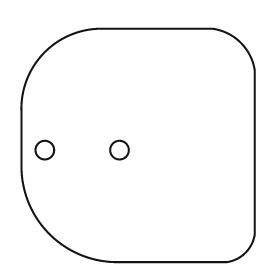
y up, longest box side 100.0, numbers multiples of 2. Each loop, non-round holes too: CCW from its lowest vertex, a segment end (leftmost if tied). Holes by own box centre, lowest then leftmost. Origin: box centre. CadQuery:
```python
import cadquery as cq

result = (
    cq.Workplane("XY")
    .moveTo(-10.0, -50.0)
    .lineTo(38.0, -50.0)
    .threePointArc((46.0, -46.0), (50.0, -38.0))
    .lineTo(50.0, 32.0)
    .threePointArc((44.0, 44.0), (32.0, 50.0))
    .lineTo(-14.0, 50.0)
    .threePointArc((-40.0, 40.0), (-50.0, 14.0))
    .lineTo(-50.0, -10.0)
    .threePointArc((-38.0, -38.0), (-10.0, -50.0))
    .close()
    .moveTo(-40.0, -2.0)
    .circle(4.0)
    .moveTo(-8.0, -2.0)
    .circle(4.0)
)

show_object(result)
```